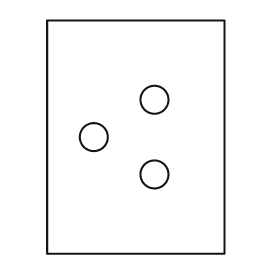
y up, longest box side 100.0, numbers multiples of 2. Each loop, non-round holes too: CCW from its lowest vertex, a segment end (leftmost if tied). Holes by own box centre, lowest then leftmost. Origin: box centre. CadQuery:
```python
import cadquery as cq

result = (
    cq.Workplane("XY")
    .moveTo(-38.0, -50.0)
    .lineTo(38.0, -50.0)
    .lineTo(38.0, 50.0)
    .lineTo(-38.0, 50.0)
    .close()
    .moveTo(8.0, -16.0)
    .circle(6.0)
    .moveTo(-18.0, 0.0)
    .circle(6.0)
    .moveTo(8.0, 16.0)
    .circle(6.0)
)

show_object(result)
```